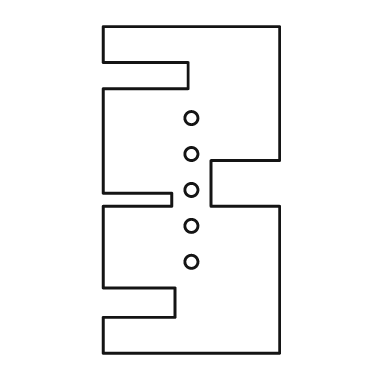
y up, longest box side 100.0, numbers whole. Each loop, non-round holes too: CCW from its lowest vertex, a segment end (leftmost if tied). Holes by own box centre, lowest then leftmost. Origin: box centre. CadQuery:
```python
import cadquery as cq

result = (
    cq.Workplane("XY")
    .moveTo(-27.0, -50.0)
    .lineTo(27.0, -50.0)
    .lineTo(27.0, -5.0)
    .lineTo(6.0, -5.0)
    .lineTo(6.0, 9.0)
    .lineTo(27.0, 9.0)
    .lineTo(27.0, 50.0)
    .lineTo(-27.0, 50.0)
    .lineTo(-27.0, 39.0)
    .lineTo(-1.0, 39.0)
    .lineTo(-1.0, 31.0)
    .lineTo(-27.0, 31.0)
    .lineTo(-27.0, -1.0)
    .lineTo(-6.0, -1.0)
    .lineTo(-6.0, -5.0)
    .lineTo(-27.0, -5.0)
    .lineTo(-27.0, -30.0)
    .lineTo(-5.0, -30.0)
    .lineTo(-5.0, -39.0)
    .lineTo(-27.0, -39.0)
    .close()
    .moveTo(0.0, -22.0)
    .circle(2.0)
    .moveTo(0.0, -11.0)
    .circle(2.0)
    .moveTo(0.0, 0.0)
    .circle(2.0)
    .moveTo(0.0, 11.0)
    .circle(2.0)
    .moveTo(0.0, 22.0)
    .circle(2.0)
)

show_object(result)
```